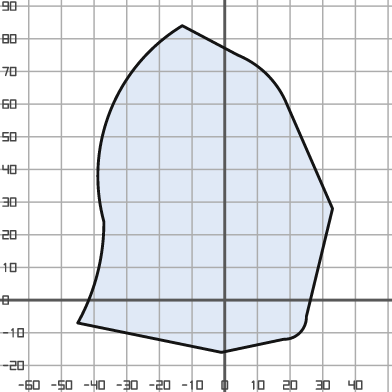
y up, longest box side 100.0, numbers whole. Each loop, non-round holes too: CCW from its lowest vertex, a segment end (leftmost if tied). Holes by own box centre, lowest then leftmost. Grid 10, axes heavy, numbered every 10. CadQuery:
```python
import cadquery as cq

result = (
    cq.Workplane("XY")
    .moveTo(-1.0, -16.0)
    .lineTo(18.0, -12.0)
    .threePointArc((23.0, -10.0), (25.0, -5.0))
    .lineTo(33.0, 28.0)
    .lineTo(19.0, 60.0)
    .threePointArc((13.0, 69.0), (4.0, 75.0))
    .lineTo(-13.0, 84.0)
    .threePointArc((-35.0, 58.0), (-37.0, 24.0))
    .threePointArc((-39.0, 8.0), (-45.0, -7.0))
    .close()
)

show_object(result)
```